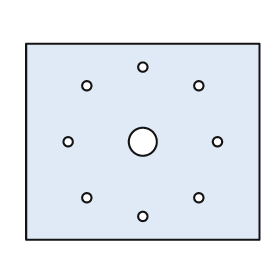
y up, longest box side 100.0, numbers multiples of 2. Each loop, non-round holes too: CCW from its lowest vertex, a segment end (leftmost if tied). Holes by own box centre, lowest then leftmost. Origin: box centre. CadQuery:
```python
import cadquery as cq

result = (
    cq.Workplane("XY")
    .moveTo(-50.0, -42.0)
    .lineTo(50.0, -42.0)
    .lineTo(50.0, 42.0)
    .lineTo(-50.0, 42.0)
    .close()
    .moveTo(0.0, -32.0)
    .circle(2.0)
    .moveTo(-24.0, -24.0)
    .circle(2.0)
    .moveTo(24.0, -24.0)
    .circle(2.0)
    .moveTo(-32.0, 0.0)
    .circle(2.0)
    .moveTo(0.0, 0.0)
    .circle(6.0)
    .moveTo(32.0, 0.0)
    .circle(2.0)
    .moveTo(-24.0, 24.0)
    .circle(2.0)
    .moveTo(24.0, 24.0)
    .circle(2.0)
    .moveTo(0.0, 32.0)
    .circle(2.0)
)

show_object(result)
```